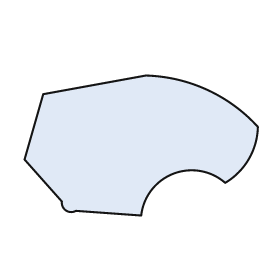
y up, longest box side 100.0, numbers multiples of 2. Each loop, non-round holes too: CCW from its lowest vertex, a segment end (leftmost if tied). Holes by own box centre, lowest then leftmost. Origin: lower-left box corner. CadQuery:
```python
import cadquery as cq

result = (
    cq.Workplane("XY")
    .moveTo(50.0, 0.0)
    .threePointArc((64.0, 18.0), (86.0, 14.0))
    .threePointArc((96.0, 24.0), (100.0, 38.0))
    .threePointArc((78.0, 54.0), (52.0, 60.0))
    .lineTo(8.0, 52.0)
    .lineTo(0.0, 24.0)
    .lineTo(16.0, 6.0)
    .threePointArc((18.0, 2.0), (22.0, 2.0))
    .close()
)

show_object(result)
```